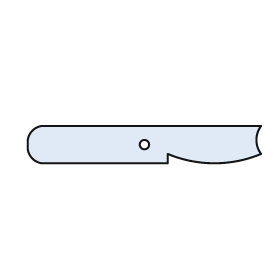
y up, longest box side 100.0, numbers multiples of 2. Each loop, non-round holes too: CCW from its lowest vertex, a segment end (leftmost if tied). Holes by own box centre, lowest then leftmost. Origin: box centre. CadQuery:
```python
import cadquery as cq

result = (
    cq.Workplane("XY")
    .moveTo(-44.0, -8.0)
    .lineTo(10.0, -8.0)
    .lineTo(10.0, -4.0)
    .threePointArc((30.0, -8.0), (50.0, -4.0))
    .threePointArc((48.0, 2.0), (50.0, 8.0))
    .lineTo(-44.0, 8.0)
    .threePointArc((-48.0, 6.0), (-50.0, 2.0))
    .lineTo(-50.0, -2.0)
    .threePointArc((-48.0, -6.0), (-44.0, -8.0))
    .close()
    .moveTo(0.0, 0.0)
    .circle(2.0)
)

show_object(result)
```